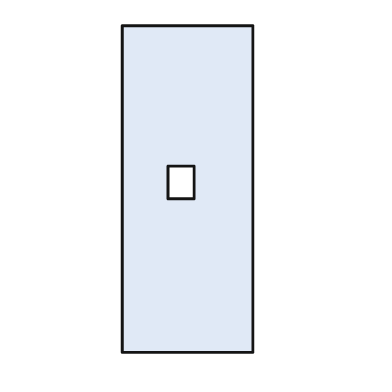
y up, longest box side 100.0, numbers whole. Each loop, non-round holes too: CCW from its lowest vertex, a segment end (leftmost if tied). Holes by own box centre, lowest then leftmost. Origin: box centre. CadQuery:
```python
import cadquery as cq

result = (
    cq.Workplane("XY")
    .moveTo(-20.0, -50.0)
    .lineTo(20.0, -50.0)
    .lineTo(20.0, 50.0)
    .lineTo(-20.0, 50.0)
    .close()
    .moveTo(-6.0, -3.0)
    .lineTo(2.0, -3.0)
    .lineTo(2.0, 7.0)
    .lineTo(-6.0, 7.0)
    .close()
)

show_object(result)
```